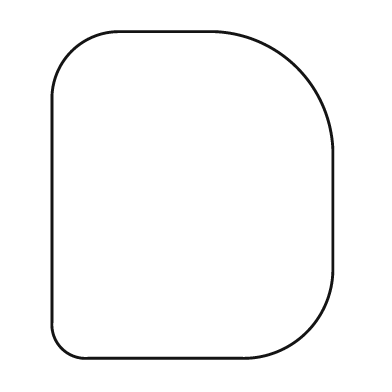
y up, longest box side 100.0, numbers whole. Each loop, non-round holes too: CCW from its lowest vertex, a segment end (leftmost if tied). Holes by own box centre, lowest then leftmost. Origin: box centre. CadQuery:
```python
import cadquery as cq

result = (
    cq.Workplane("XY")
    .moveTo(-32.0, -50.0)
    .lineTo(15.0, -50.0)
    .threePointArc((35.0, -42.0), (43.0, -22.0))
    .lineTo(43.0, 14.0)
    .threePointArc((32.0, 39.0), (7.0, 50.0))
    .lineTo(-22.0, 50.0)
    .threePointArc((-37.0, 44.0), (-43.0, 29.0))
    .lineTo(-43.0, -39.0)
    .threePointArc((-40.0, -47.0), (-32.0, -50.0))
    .close()
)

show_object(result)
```